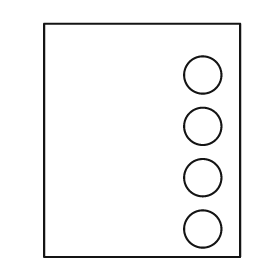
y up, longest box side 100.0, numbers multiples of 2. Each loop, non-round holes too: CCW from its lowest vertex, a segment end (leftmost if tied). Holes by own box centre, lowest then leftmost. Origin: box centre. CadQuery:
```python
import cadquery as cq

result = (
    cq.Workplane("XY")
    .moveTo(-42.0, -50.0)
    .lineTo(42.0, -50.0)
    .lineTo(42.0, 50.0)
    .lineTo(-42.0, 50.0)
    .close()
    .moveTo(26.0, -38.0)
    .circle(8.0)
    .moveTo(26.0, -16.0)
    .circle(8.0)
    .moveTo(26.0, 6.0)
    .circle(8.0)
    .moveTo(26.0, 28.0)
    .circle(8.0)
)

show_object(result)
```